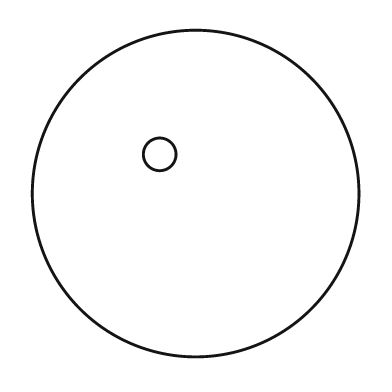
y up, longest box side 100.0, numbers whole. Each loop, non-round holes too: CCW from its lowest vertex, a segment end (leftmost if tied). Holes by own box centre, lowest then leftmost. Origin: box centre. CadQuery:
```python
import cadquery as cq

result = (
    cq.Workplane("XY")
    .moveTo(0.0, 0.0)
    .circle(50.0)
    .moveTo(-11.0, 12.0)
    .circle(5.0)
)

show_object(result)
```